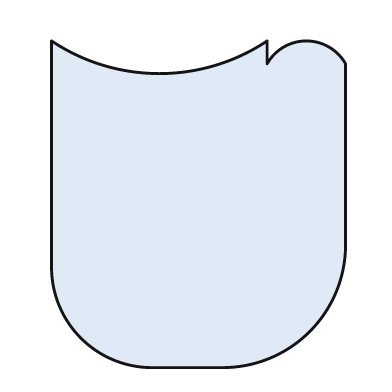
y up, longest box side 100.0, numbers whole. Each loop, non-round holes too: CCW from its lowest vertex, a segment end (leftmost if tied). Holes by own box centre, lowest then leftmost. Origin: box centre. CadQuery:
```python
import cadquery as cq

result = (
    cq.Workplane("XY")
    .moveTo(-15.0, -50.0)
    .lineTo(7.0, -50.0)
    .threePointArc((34.0, -39.0), (45.0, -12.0))
    .lineTo(45.0, 43.0)
    .threePointArc((33.0, 50.0), (21.0, 43.0))
    .lineTo(21.0, 50.0)
    .threePointArc((-12.0, 40.0), (-45.0, 50.0))
    .lineTo(-45.0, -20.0)
    .threePointArc((-36.0, -41.0), (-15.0, -50.0))
    .close()
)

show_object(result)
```